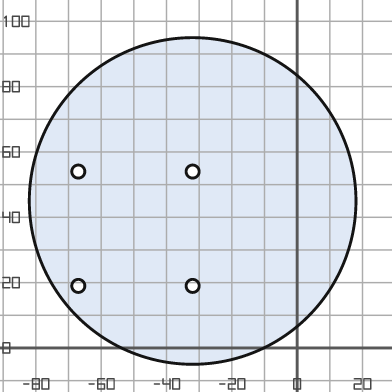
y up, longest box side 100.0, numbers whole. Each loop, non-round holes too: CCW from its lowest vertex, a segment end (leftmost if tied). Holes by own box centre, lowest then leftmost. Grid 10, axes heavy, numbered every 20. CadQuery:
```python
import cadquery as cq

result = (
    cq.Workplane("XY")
    .moveTo(-32.0, 45.0)
    .circle(50.0)
    .moveTo(-67.0, 19.0)
    .circle(2.0)
    .moveTo(-32.0, 19.0)
    .circle(2.0)
    .moveTo(-67.0, 54.0)
    .circle(2.0)
    .moveTo(-32.0, 54.0)
    .circle(2.0)
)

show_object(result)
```